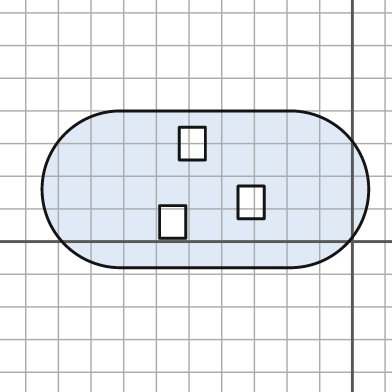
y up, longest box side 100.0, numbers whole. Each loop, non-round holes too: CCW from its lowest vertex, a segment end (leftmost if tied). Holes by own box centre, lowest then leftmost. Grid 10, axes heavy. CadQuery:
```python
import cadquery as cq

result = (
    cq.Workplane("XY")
    .moveTo(-71.0, -8.0)
    .lineTo(-19.0, -8.0)
    .threePointArc((5.0, 16.0), (-19.0, 40.0))
    .lineTo(-71.0, 40.0)
    .threePointArc((-95.0, 16.0), (-71.0, -8.0))
    .close()
    .moveTo(-59.0, 1.0)
    .lineTo(-51.0, 1.0)
    .lineTo(-51.0, 11.0)
    .lineTo(-59.0, 11.0)
    .close()
    .moveTo(-35.0, 7.0)
    .lineTo(-27.0, 7.0)
    .lineTo(-27.0, 17.0)
    .lineTo(-35.0, 17.0)
    .close()
    .moveTo(-53.0, 25.0)
    .lineTo(-45.0, 25.0)
    .lineTo(-45.0, 35.0)
    .lineTo(-53.0, 35.0)
    .close()
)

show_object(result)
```